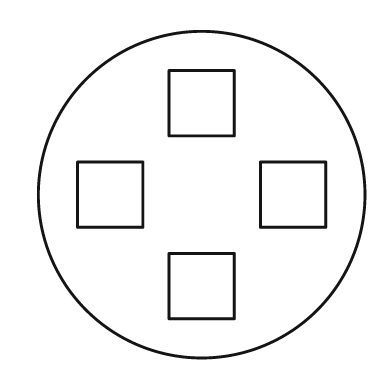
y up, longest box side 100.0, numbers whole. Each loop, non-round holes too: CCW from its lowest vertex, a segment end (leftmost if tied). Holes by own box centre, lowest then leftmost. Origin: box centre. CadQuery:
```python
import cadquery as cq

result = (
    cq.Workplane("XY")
    .moveTo(0.0, 0.0)
    .circle(50.0)
    .moveTo(-10.0, -38.0)
    .lineTo(10.0, -38.0)
    .lineTo(10.0, -18.0)
    .lineTo(-10.0, -18.0)
    .close()
    .moveTo(-38.0, -10.0)
    .lineTo(-18.0, -10.0)
    .lineTo(-18.0, 10.0)
    .lineTo(-38.0, 10.0)
    .close()
    .moveTo(18.0, -10.0)
    .lineTo(38.0, -10.0)
    .lineTo(38.0, 10.0)
    .lineTo(18.0, 10.0)
    .close()
    .moveTo(-10.0, 18.0)
    .lineTo(10.0, 18.0)
    .lineTo(10.0, 38.0)
    .lineTo(-10.0, 38.0)
    .close()
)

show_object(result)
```